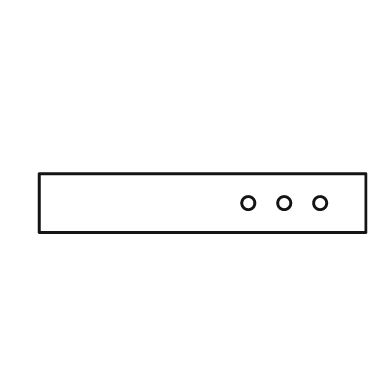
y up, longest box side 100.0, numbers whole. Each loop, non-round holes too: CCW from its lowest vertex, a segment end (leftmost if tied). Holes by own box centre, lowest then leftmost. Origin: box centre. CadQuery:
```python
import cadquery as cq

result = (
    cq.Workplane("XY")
    .moveTo(-50.0, -9.0)
    .lineTo(50.0, -9.0)
    .lineTo(50.0, 9.0)
    .lineTo(-50.0, 9.0)
    .close()
    .moveTo(14.0, 0.0)
    .circle(2.0)
    .moveTo(25.0, 0.0)
    .circle(2.0)
    .moveTo(36.0, 0.0)
    .circle(2.0)
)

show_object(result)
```